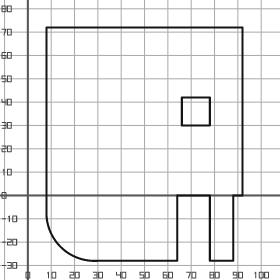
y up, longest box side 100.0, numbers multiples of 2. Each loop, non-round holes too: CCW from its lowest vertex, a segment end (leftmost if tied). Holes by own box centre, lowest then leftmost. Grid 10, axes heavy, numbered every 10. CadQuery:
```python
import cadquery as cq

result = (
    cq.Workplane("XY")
    .moveTo(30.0, -28.0)
    .lineTo(64.0, -28.0)
    .lineTo(64.0, 0.0)
    .lineTo(78.0, 0.0)
    .lineTo(78.0, -28.0)
    .lineTo(88.0, -28.0)
    .lineTo(88.0, 0.0)
    .lineTo(92.0, 0.0)
    .lineTo(92.0, 72.0)
    .lineTo(8.0, 72.0)
    .lineTo(8.0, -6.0)
    .threePointArc((14.0, -22.0), (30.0, -28.0))
    .close()
    .moveTo(66.0, 30.0)
    .lineTo(78.0, 30.0)
    .lineTo(78.0, 42.0)
    .lineTo(66.0, 42.0)
    .close()
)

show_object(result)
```